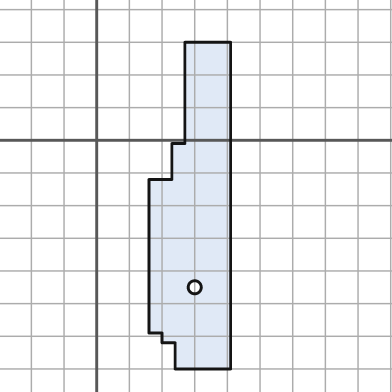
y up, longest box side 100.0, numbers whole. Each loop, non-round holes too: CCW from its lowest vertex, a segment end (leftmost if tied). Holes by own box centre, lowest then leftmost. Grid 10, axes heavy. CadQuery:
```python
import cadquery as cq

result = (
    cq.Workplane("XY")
    .moveTo(24.0, -70.0)
    .lineTo(41.0, -70.0)
    .lineTo(41.0, 30.0)
    .lineTo(27.0, 30.0)
    .lineTo(27.0, -1.0)
    .lineTo(23.0, -1.0)
    .lineTo(23.0, -12.0)
    .lineTo(16.0, -12.0)
    .lineTo(16.0, -59.0)
    .lineTo(20.0, -59.0)
    .lineTo(20.0, -62.0)
    .lineTo(24.0, -62.0)
    .close()
    .moveTo(30.0, -45.0)
    .circle(2.0)
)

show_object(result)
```